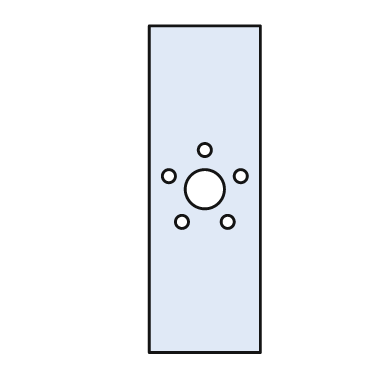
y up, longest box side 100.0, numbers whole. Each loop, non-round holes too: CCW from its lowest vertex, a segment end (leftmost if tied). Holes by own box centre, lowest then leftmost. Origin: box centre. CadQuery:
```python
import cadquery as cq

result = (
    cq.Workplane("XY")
    .moveTo(-17.0, -50.0)
    .lineTo(17.0, -50.0)
    .lineTo(17.0, 50.0)
    .lineTo(-17.0, 50.0)
    .close()
    .moveTo(-7.0, -10.0)
    .circle(2.0)
    .moveTo(7.0, -10.0)
    .circle(2.0)
    .moveTo(0.0, 0.0)
    .circle(6.0)
    .moveTo(-11.0, 4.0)
    .circle(2.0)
    .moveTo(11.0, 4.0)
    .circle(2.0)
    .moveTo(0.0, 12.0)
    .circle(2.0)
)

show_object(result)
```